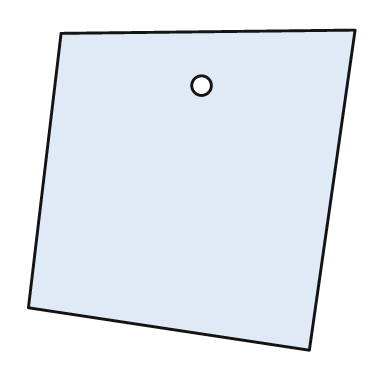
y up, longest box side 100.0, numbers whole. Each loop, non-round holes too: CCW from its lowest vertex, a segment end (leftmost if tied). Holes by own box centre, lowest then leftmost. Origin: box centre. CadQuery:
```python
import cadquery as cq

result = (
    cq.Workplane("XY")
    .moveTo(36.0, -49.0)
    .lineTo(50.0, 49.0)
    .lineTo(-40.0, 48.0)
    .lineTo(-50.0, -36.0)
    .close()
    .moveTo(3.0, 32.0)
    .circle(3.0)
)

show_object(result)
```